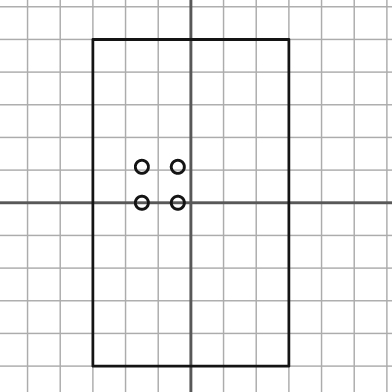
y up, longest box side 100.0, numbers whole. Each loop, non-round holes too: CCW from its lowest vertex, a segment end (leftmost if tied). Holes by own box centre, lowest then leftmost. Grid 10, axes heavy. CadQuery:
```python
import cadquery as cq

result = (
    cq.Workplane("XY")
    .moveTo(-30.0, -50.0)
    .lineTo(30.0, -50.0)
    .lineTo(30.0, 50.0)
    .lineTo(-30.0, 50.0)
    .close()
    .moveTo(-15.0, 0.0)
    .circle(2.0)
    .moveTo(-4.0, 0.0)
    .circle(2.0)
    .moveTo(-15.0, 11.0)
    .circle(2.0)
    .moveTo(-4.0, 11.0)
    .circle(2.0)
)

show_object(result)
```